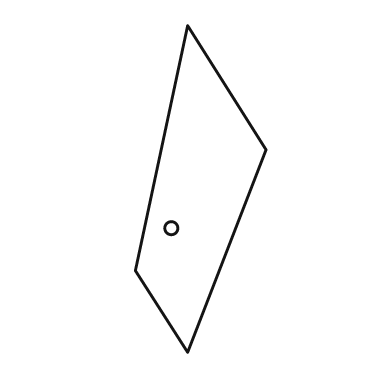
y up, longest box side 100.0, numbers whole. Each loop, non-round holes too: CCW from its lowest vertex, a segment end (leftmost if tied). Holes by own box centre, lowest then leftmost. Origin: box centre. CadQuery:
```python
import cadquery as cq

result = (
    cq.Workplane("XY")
    .moveTo(-4.0, -50.0)
    .lineTo(20.0, 12.0)
    .lineTo(-4.0, 50.0)
    .lineTo(-20.0, -25.0)
    .close()
    .moveTo(-9.0, -12.0)
    .circle(2.0)
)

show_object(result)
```